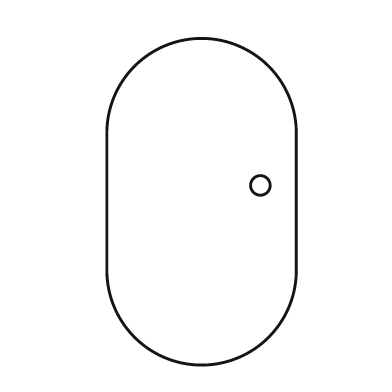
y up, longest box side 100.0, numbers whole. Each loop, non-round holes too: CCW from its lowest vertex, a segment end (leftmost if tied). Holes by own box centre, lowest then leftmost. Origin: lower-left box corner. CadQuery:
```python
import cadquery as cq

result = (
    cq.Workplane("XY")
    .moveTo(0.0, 29.0)
    .threePointArc((29.0, 0.0), (58.0, 29.0))
    .lineTo(58.0, 71.0)
    .threePointArc((29.0, 100.0), (0.0, 71.0))
    .close()
    .moveTo(47.0, 55.0)
    .circle(3.0)
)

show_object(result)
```